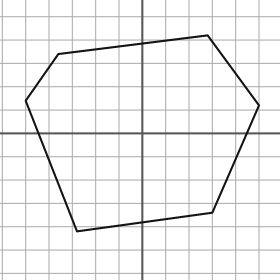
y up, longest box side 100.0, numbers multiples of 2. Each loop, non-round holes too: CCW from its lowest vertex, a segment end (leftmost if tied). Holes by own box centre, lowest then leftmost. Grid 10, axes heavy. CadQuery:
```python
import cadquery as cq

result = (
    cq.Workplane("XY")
    .moveTo(-28.0, -42.0)
    .lineTo(30.0, -34.0)
    .lineTo(50.0, 12.0)
    .lineTo(28.0, 42.0)
    .lineTo(-36.0, 34.0)
    .lineTo(-50.0, 14.0)
    .close()
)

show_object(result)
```